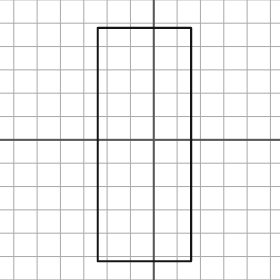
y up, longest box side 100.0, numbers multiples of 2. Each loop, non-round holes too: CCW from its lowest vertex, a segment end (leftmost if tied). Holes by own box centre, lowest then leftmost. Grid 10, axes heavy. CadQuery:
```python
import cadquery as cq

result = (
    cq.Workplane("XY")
    .moveTo(-24.0, -52.0)
    .lineTo(16.0, -52.0)
    .lineTo(16.0, 48.0)
    .lineTo(-24.0, 48.0)
    .close()
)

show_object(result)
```